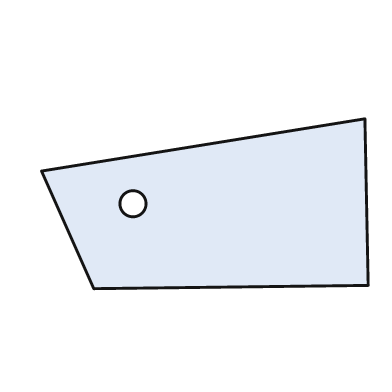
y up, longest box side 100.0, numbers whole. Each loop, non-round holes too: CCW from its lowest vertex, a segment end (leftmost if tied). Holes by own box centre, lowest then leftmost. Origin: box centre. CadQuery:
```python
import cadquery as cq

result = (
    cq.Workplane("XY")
    .moveTo(-34.0, -26.0)
    .lineTo(50.0, -25.0)
    .lineTo(49.0, 26.0)
    .lineTo(-50.0, 10.0)
    .close()
    .moveTo(-22.0, 0.0)
    .circle(4.0)
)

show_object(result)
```